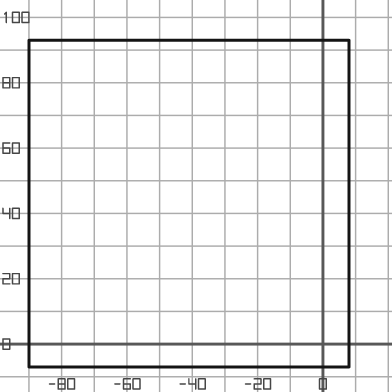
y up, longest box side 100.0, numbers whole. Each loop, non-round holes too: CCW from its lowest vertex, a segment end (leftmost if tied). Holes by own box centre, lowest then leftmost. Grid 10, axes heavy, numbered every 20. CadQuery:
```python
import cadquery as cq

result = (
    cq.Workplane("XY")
    .moveTo(-90.0, -7.0)
    .lineTo(8.0, -7.0)
    .lineTo(8.0, 93.0)
    .lineTo(-90.0, 93.0)
    .close()
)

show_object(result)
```